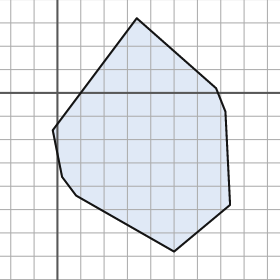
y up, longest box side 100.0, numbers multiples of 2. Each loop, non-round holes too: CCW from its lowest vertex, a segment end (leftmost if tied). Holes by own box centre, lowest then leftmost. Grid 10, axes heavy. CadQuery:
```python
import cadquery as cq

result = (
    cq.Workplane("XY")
    .moveTo(50.0, -68.0)
    .lineTo(74.0, -48.0)
    .lineTo(72.0, -8.0)
    .lineTo(68.0, 2.0)
    .lineTo(34.0, 32.0)
    .lineTo(-2.0, -16.0)
    .lineTo(2.0, -36.0)
    .lineTo(8.0, -44.0)
    .close()
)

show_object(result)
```